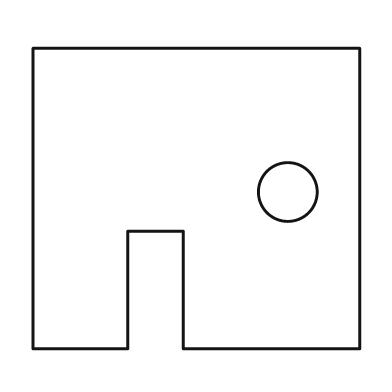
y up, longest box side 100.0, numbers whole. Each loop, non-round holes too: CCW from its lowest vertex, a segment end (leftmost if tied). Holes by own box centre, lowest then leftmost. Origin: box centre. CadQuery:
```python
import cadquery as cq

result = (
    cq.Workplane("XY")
    .moveTo(-50.0, -46.0)
    .lineTo(-21.0, -46.0)
    .lineTo(-21.0, -10.0)
    .lineTo(-4.0, -10.0)
    .lineTo(-4.0, -46.0)
    .lineTo(50.0, -46.0)
    .lineTo(50.0, 46.0)
    .lineTo(-50.0, 46.0)
    .close()
    .moveTo(28.0, 2.0)
    .circle(9.0)
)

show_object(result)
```